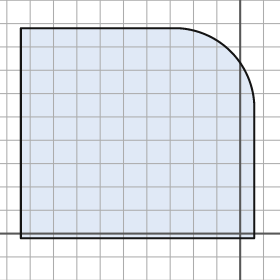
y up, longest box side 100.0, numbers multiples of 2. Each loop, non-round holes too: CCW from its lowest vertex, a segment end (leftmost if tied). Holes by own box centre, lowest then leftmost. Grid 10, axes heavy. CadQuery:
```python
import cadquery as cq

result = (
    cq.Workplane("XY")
    .moveTo(-94.0, -2.0)
    .lineTo(6.0, -2.0)
    .lineTo(6.0, 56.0)
    .threePointArc((-4.0, 78.0), (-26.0, 88.0))
    .lineTo(-94.0, 88.0)
    .close()
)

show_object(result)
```